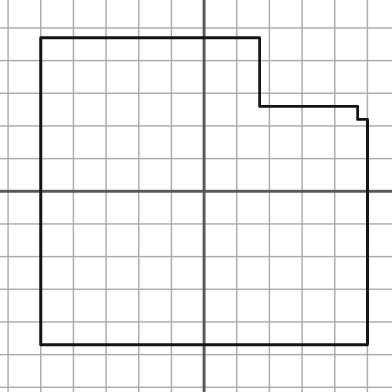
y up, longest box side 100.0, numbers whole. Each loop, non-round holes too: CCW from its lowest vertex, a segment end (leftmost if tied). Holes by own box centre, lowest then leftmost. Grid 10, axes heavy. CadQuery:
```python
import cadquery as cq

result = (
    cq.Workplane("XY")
    .moveTo(-50.0, -47.0)
    .lineTo(50.0, -47.0)
    .lineTo(50.0, 22.0)
    .lineTo(47.0, 22.0)
    .lineTo(47.0, 26.0)
    .lineTo(17.0, 26.0)
    .lineTo(17.0, 47.0)
    .lineTo(-50.0, 47.0)
    .close()
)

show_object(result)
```